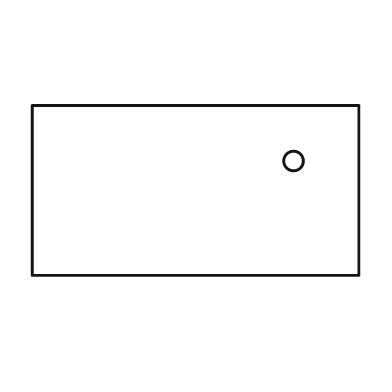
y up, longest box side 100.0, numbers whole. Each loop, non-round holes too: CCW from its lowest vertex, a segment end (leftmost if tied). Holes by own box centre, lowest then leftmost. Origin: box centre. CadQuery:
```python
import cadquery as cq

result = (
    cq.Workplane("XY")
    .moveTo(-50.0, -26.0)
    .lineTo(50.0, -26.0)
    .lineTo(50.0, 26.0)
    .lineTo(-50.0, 26.0)
    .close()
    .moveTo(30.0, 9.0)
    .circle(3.0)
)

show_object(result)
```